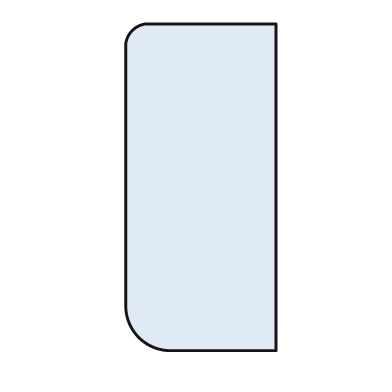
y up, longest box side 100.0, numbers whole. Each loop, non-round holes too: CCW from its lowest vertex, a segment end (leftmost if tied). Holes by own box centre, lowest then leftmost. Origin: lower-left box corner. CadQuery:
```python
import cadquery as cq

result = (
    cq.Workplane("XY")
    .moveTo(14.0, 0.0)
    .lineTo(46.0, 0.0)
    .lineTo(46.0, 100.0)
    .lineTo(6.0, 100.0)
    .threePointArc((2.0, 98.0), (0.0, 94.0))
    .lineTo(0.0, 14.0)
    .threePointArc((4.0, 4.0), (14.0, 0.0))
    .close()
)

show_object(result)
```